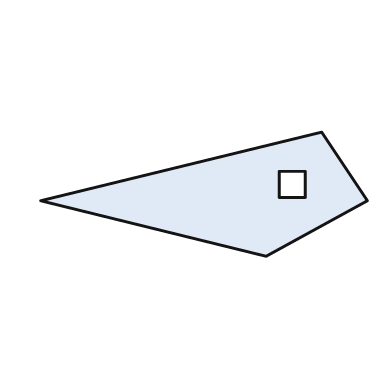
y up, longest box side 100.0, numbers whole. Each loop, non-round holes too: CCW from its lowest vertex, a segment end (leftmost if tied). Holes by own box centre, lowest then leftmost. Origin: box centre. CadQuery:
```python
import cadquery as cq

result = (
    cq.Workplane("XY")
    .moveTo(19.0, -19.0)
    .lineTo(50.0, -2.0)
    .lineTo(36.0, 19.0)
    .lineTo(-50.0, -2.0)
    .close()
    .moveTo(23.0, -1.0)
    .lineTo(31.0, -1.0)
    .lineTo(31.0, 7.0)
    .lineTo(23.0, 7.0)
    .close()
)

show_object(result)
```